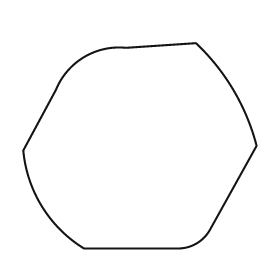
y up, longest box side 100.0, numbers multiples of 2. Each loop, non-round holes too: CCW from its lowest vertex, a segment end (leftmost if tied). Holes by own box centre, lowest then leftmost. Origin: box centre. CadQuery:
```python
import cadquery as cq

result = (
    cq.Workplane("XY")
    .moveTo(-24.0, -44.0)
    .lineTo(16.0, -44.0)
    .threePointArc((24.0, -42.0), (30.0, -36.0))
    .lineTo(50.0, 0.0)
    .threePointArc((40.0, 24.0), (24.0, 44.0))
    .lineTo(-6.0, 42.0)
    .threePointArc((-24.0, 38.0), (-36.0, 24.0))
    .lineTo(-50.0, -2.0)
    .threePointArc((-42.0, -26.0), (-24.0, -44.0))
    .close()
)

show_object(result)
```